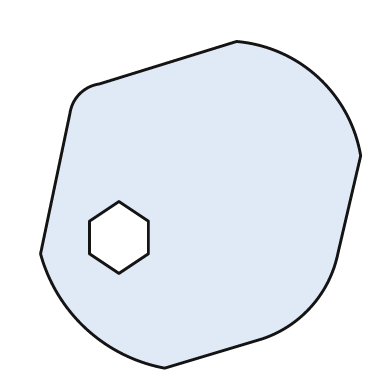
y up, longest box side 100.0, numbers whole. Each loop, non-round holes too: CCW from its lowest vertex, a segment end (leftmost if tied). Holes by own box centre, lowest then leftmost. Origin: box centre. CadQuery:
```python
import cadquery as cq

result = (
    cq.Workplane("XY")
    .moveTo(-11.0, -50.0)
    .lineTo(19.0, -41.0)
    .threePointArc((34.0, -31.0), (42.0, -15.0))
    .lineTo(49.0, 15.0)
    .threePointArc((36.0, 39.0), (11.0, 50.0))
    .lineTo(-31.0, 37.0)
    .threePointArc((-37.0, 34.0), (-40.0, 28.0))
    .lineTo(-49.0, -15.0)
    .threePointArc((-35.0, -38.0), (-11.0, -50.0))
    .close()
    .moveTo(-25.0, -21.0)
    .lineTo(-16.0, -15.0)
    .lineTo(-16.0, -5.0)
    .lineTo(-25.0, 1.0)
    .lineTo(-34.0, -5.0)
    .lineTo(-34.0, -15.0)
    .close()
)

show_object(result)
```